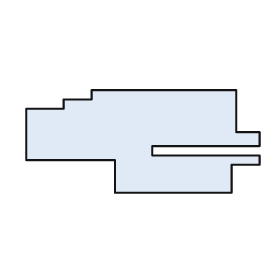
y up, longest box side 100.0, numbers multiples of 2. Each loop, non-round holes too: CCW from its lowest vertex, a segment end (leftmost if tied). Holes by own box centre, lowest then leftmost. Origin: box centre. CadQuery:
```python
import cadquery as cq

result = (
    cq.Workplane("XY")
    .moveTo(-12.0, -22.0)
    .lineTo(38.0, -22.0)
    .lineTo(38.0, -10.0)
    .lineTo(50.0, -10.0)
    .lineTo(50.0, -6.0)
    .lineTo(4.0, -6.0)
    .lineTo(4.0, -2.0)
    .lineTo(50.0, -2.0)
    .lineTo(50.0, 4.0)
    .lineTo(40.0, 4.0)
    .lineTo(40.0, 22.0)
    .lineTo(-22.0, 22.0)
    .lineTo(-22.0, 18.0)
    .lineTo(-34.0, 18.0)
    .lineTo(-34.0, 14.0)
    .lineTo(-50.0, 14.0)
    .lineTo(-50.0, -8.0)
    .lineTo(-12.0, -8.0)
    .close()
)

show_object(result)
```